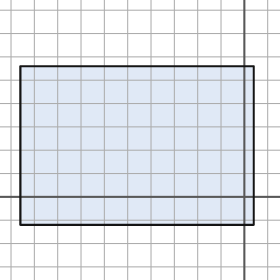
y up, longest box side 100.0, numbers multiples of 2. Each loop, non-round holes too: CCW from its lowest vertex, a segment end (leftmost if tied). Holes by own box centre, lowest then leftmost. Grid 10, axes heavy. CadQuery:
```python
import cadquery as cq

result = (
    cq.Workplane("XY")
    .moveTo(-96.0, -12.0)
    .lineTo(4.0, -12.0)
    .lineTo(4.0, 56.0)
    .lineTo(-96.0, 56.0)
    .close()
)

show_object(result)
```